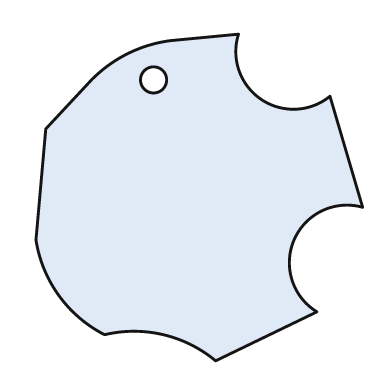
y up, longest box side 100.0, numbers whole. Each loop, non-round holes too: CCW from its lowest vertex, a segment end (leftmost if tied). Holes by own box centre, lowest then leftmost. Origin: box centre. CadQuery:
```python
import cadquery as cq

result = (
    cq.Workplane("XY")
    .moveTo(5.0, -50.0)
    .lineTo(36.0, -35.0)
    .threePointArc((29.0, -13.0), (50.0, -3.0))
    .lineTo(40.0, 31.0)
    .threePointArc((19.0, 30.0), (12.0, 50.0))
    .lineTo(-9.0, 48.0)
    .threePointArc((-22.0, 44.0), (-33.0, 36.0))
    .lineTo(-47.0, 21.0)
    .lineTo(-50.0, -13.0)
    .threePointArc((-43.0, -30.0), (-29.0, -42.0))
    .threePointArc((-11.0, -42.0), (5.0, -50.0))
    .close()
    .moveTo(-14.0, 36.0)
    .circle(4.0)
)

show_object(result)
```